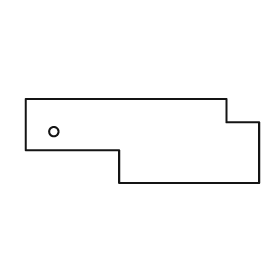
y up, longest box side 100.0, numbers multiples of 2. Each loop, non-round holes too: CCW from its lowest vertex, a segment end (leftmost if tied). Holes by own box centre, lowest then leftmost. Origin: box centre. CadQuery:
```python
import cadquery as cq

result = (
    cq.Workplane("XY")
    .moveTo(-10.0, -18.0)
    .lineTo(50.0, -18.0)
    .lineTo(50.0, 8.0)
    .lineTo(36.0, 8.0)
    .lineTo(36.0, 18.0)
    .lineTo(-50.0, 18.0)
    .lineTo(-50.0, -4.0)
    .lineTo(-10.0, -4.0)
    .close()
    .moveTo(-38.0, 4.0)
    .circle(2.0)
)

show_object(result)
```